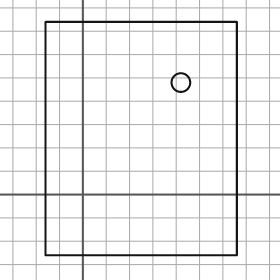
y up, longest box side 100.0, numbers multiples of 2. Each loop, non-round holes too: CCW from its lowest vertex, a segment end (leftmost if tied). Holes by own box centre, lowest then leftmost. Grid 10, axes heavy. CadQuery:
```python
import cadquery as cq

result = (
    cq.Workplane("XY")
    .moveTo(-16.0, -26.0)
    .lineTo(66.0, -26.0)
    .lineTo(66.0, 74.0)
    .lineTo(-16.0, 74.0)
    .close()
    .moveTo(42.0, 48.0)
    .circle(4.0)
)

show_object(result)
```